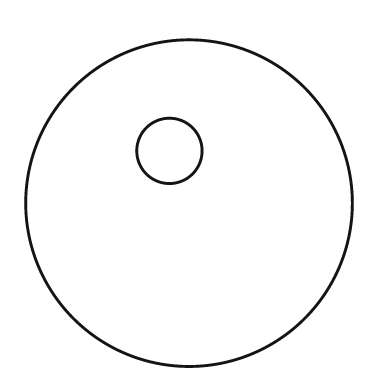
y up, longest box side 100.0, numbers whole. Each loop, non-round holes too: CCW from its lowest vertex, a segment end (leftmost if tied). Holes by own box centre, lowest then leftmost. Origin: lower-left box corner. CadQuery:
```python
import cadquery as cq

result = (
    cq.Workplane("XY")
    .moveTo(50.0, 50.0)
    .circle(50.0)
    .moveTo(44.0, 66.0)
    .circle(10.0)
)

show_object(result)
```